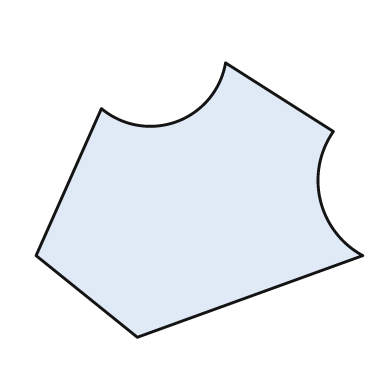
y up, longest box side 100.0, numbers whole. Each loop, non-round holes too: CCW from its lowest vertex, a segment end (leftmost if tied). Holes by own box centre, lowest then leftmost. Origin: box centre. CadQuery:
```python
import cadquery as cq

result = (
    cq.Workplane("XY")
    .moveTo(-19.0, -42.0)
    .lineTo(50.0, -17.0)
    .threePointArc((37.0, 0.0), (41.0, 21.0))
    .lineTo(8.0, 42.0)
    .threePointArc((-7.0, 24.0), (-30.0, 28.0))
    .lineTo(-50.0, -17.0)
    .close()
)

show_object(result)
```